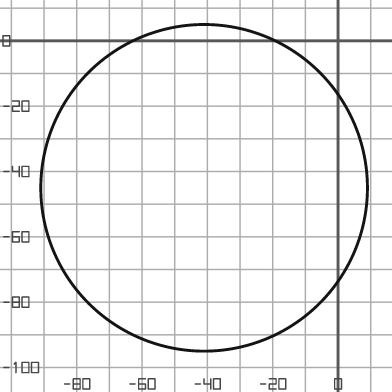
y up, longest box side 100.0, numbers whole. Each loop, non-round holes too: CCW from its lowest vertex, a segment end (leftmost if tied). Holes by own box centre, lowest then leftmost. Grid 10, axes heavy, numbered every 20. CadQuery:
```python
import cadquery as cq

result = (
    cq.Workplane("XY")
    .moveTo(-41.0, -45.0)
    .circle(50.0)
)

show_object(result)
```